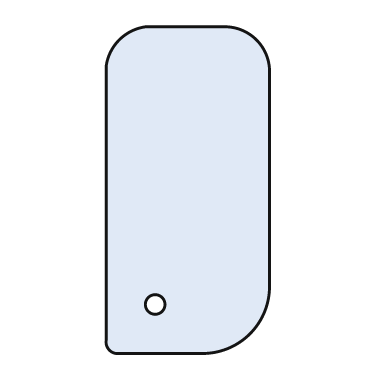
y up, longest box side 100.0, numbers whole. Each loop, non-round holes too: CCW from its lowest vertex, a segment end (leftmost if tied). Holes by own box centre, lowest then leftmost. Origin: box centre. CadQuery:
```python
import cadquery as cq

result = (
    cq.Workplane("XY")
    .moveTo(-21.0, -50.0)
    .lineTo(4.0, -50.0)
    .threePointArc((19.0, -44.0), (25.0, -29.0))
    .lineTo(25.0, 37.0)
    .threePointArc((21.0, 46.0), (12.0, 50.0))
    .lineTo(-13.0, 50.0)
    .threePointArc((-21.0, 46.0), (-25.0, 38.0))
    .lineTo(-25.0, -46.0)
    .threePointArc((-24.0, -49.0), (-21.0, -50.0))
    .close()
    .moveTo(-10.0, -35.0)
    .circle(3.0)
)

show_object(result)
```